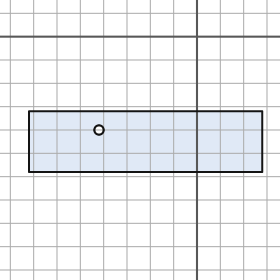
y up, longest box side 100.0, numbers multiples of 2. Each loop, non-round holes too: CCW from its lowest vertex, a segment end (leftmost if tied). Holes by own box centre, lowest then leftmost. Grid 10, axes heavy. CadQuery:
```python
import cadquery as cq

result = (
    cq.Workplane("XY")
    .moveTo(-72.0, -58.0)
    .lineTo(28.0, -58.0)
    .lineTo(28.0, -32.0)
    .lineTo(-72.0, -32.0)
    .close()
    .moveTo(-42.0, -40.0)
    .circle(2.0)
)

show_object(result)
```